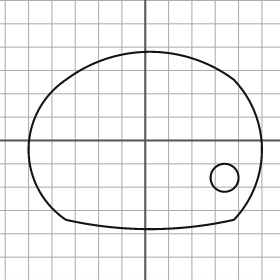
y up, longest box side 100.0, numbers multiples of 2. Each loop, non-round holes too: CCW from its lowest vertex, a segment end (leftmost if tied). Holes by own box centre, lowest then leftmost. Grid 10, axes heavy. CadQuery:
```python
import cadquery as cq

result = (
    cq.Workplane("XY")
    .moveTo(-34.0, -34.0)
    .threePointArc((2.0, -38.0), (38.0, -34.0))
    .threePointArc((50.0, -4.0), (38.0, 26.0))
    .threePointArc((2.0, 38.0), (-34.0, 26.0))
    .threePointArc((-50.0, -4.0), (-34.0, -34.0))
    .close()
    .moveTo(34.0, -16.0)
    .circle(6.0)
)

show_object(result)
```